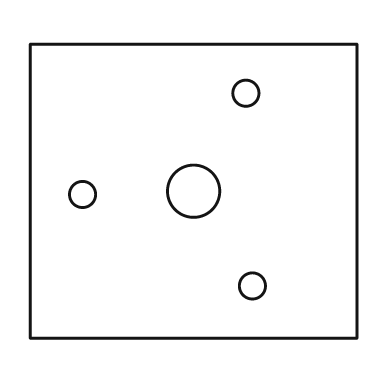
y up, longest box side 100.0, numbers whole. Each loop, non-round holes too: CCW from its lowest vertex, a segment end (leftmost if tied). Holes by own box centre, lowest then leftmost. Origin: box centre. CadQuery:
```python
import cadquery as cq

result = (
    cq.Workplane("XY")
    .moveTo(-50.0, -45.0)
    .lineTo(50.0, -45.0)
    .lineTo(50.0, 45.0)
    .lineTo(-50.0, 45.0)
    .close()
    .moveTo(18.0, -29.0)
    .circle(4.0)
    .moveTo(-34.0, -1.0)
    .circle(4.0)
    .moveTo(0.0, 0.0)
    .circle(8.0)
    .moveTo(16.0, 30.0)
    .circle(4.0)
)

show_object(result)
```